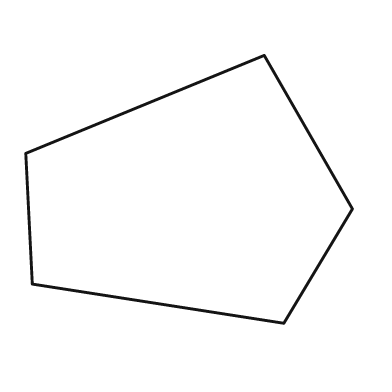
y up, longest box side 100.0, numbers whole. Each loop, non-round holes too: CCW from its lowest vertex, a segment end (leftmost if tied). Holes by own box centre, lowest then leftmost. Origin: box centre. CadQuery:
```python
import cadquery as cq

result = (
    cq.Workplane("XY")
    .moveTo(29.0, -41.0)
    .lineTo(50.0, -6.0)
    .lineTo(23.0, 41.0)
    .lineTo(-50.0, 11.0)
    .lineTo(-48.0, -29.0)
    .close()
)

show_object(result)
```